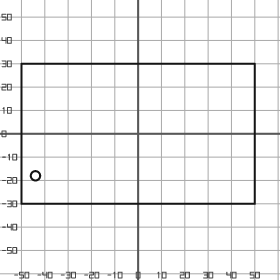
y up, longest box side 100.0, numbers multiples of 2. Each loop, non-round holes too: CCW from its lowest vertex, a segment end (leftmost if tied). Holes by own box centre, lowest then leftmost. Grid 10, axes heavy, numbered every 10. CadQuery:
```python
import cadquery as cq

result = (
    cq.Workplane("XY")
    .moveTo(-50.0, -30.0)
    .lineTo(50.0, -30.0)
    .lineTo(50.0, 30.0)
    .lineTo(-50.0, 30.0)
    .close()
    .moveTo(-44.0, -18.0)
    .circle(2.0)
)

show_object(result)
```